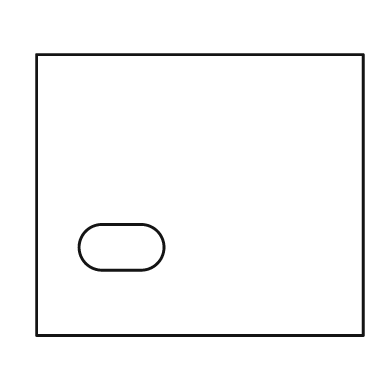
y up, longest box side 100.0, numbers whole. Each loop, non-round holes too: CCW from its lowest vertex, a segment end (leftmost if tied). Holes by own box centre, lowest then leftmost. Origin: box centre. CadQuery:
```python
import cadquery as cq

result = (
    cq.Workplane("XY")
    .moveTo(-50.0, -43.0)
    .lineTo(50.0, -43.0)
    .lineTo(50.0, 43.0)
    .lineTo(-50.0, 43.0)
    .close()
    .moveTo(-30.0, -23.0)
    .lineTo(-18.0, -23.0)
    .threePointArc((-11.0, -16.0), (-18.0, -9.0))
    .lineTo(-30.0, -9.0)
    .threePointArc((-37.0, -16.0), (-30.0, -23.0))
    .close()
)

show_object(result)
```